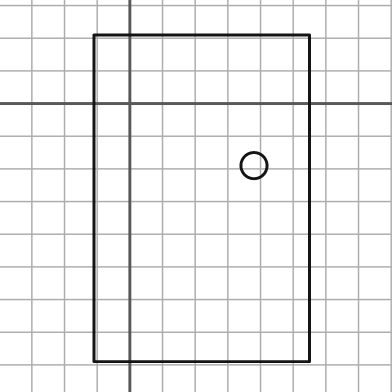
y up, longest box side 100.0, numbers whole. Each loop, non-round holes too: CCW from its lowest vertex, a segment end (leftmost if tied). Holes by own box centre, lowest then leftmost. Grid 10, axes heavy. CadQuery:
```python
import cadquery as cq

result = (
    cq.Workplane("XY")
    .moveTo(-11.0, -79.0)
    .lineTo(55.0, -79.0)
    .lineTo(55.0, 21.0)
    .lineTo(-11.0, 21.0)
    .close()
    .moveTo(38.0, -19.0)
    .circle(4.0)
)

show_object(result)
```